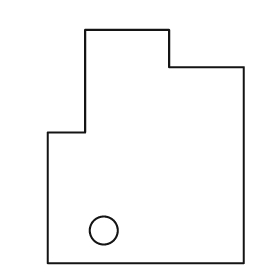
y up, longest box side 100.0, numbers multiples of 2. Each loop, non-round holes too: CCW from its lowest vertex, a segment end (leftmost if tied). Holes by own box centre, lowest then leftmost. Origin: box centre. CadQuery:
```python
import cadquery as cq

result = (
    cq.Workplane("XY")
    .moveTo(-42.0, -50.0)
    .lineTo(42.0, -50.0)
    .lineTo(42.0, 34.0)
    .lineTo(10.0, 34.0)
    .lineTo(10.0, 50.0)
    .lineTo(-26.0, 50.0)
    .lineTo(-26.0, 6.0)
    .lineTo(-42.0, 6.0)
    .close()
    .moveTo(-18.0, -36.0)
    .circle(6.0)
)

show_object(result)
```